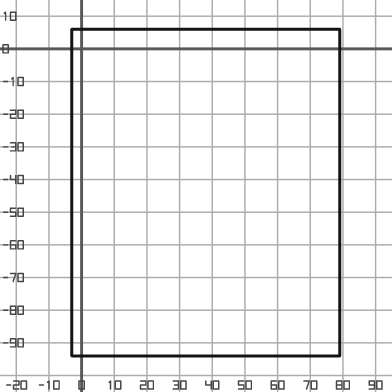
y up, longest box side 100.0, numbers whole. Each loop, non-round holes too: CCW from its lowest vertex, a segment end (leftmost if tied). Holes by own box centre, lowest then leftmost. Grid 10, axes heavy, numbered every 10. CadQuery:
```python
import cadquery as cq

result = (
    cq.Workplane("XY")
    .moveTo(-3.0, -94.0)
    .lineTo(79.0, -94.0)
    .lineTo(79.0, 6.0)
    .lineTo(-3.0, 6.0)
    .close()
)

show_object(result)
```